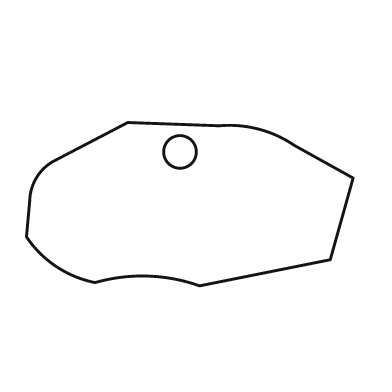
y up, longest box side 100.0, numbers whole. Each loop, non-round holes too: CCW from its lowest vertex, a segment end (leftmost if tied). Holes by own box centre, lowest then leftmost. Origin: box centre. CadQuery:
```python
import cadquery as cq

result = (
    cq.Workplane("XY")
    .moveTo(3.0, -25.0)
    .lineTo(43.0, -17.0)
    .lineTo(50.0, 8.0)
    .lineTo(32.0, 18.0)
    .threePointArc((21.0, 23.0), (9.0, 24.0))
    .lineTo(-19.0, 25.0)
    .lineTo(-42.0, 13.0)
    .threePointArc((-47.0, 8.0), (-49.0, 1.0))
    .lineTo(-50.0, -10.0)
    .threePointArc((-41.0, -19.0), (-29.0, -24.0))
    .threePointArc((-13.0, -22.0), (3.0, -25.0))
    .close()
    .moveTo(-3.0, 16.0)
    .circle(5.0)
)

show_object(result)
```